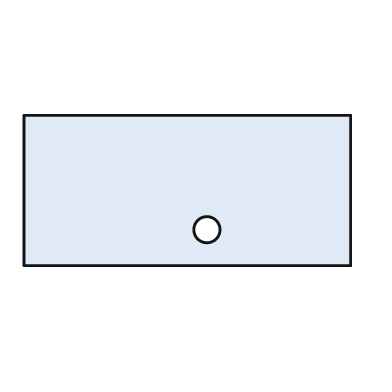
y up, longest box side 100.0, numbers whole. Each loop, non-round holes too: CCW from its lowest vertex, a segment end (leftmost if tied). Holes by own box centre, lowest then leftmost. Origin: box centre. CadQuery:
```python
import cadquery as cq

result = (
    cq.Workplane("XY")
    .moveTo(-50.0, -23.0)
    .lineTo(50.0, -23.0)
    .lineTo(50.0, 23.0)
    .lineTo(-50.0, 23.0)
    .close()
    .moveTo(6.0, -12.0)
    .circle(4.0)
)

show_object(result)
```